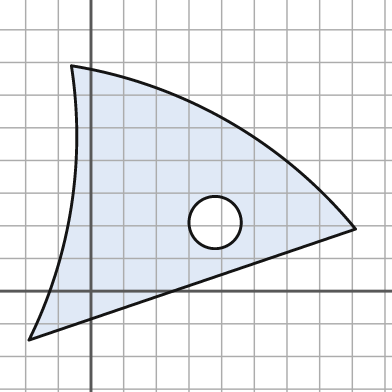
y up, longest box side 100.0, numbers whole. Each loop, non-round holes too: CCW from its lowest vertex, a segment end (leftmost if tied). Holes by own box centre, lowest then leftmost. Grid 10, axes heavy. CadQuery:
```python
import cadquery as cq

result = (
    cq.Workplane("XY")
    .moveTo(-19.0, -15.0)
    .lineTo(81.0, 19.0)
    .threePointArc((42.0, 52.0), (-6.0, 69.0))
    .threePointArc((-6.0, 26.0), (-19.0, -15.0))
    .close()
    .moveTo(38.0, 21.0)
    .circle(8.0)
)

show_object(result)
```